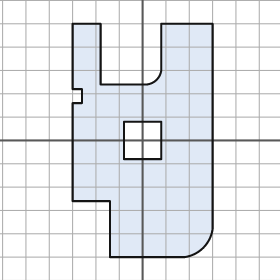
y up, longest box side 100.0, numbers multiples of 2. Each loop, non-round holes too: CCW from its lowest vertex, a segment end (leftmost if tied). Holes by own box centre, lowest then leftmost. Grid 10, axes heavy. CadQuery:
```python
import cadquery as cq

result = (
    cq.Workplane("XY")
    .moveTo(-14.0, -50.0)
    .lineTo(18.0, -50.0)
    .threePointArc((26.0, -46.0), (30.0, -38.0))
    .lineTo(30.0, 50.0)
    .lineTo(8.0, 50.0)
    .lineTo(8.0, 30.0)
    .threePointArc((6.0, 26.0), (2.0, 24.0))
    .lineTo(-18.0, 24.0)
    .lineTo(-18.0, 50.0)
    .lineTo(-30.0, 50.0)
    .lineTo(-30.0, 22.0)
    .lineTo(-26.0, 22.0)
    .lineTo(-26.0, 16.0)
    .lineTo(-30.0, 16.0)
    .lineTo(-30.0, -26.0)
    .lineTo(-14.0, -26.0)
    .close()
    .moveTo(-8.0, -8.0)
    .lineTo(8.0, -8.0)
    .lineTo(8.0, 8.0)
    .lineTo(-8.0, 8.0)
    .close()
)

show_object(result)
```